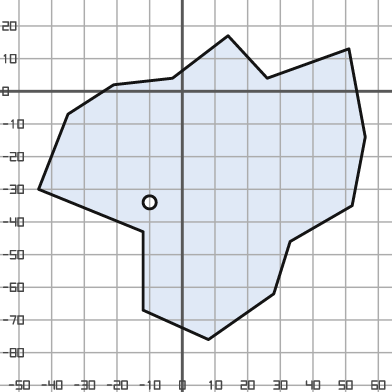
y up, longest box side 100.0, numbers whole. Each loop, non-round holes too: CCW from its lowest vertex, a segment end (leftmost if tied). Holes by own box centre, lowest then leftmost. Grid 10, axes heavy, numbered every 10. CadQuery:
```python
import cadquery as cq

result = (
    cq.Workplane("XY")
    .moveTo(8.0, -76.0)
    .lineTo(28.0, -62.0)
    .lineTo(33.0, -46.0)
    .lineTo(52.0, -35.0)
    .lineTo(56.0, -14.0)
    .lineTo(51.0, 13.0)
    .lineTo(26.0, 4.0)
    .lineTo(14.0, 17.0)
    .lineTo(-3.0, 4.0)
    .lineTo(-21.0, 2.0)
    .lineTo(-35.0, -7.0)
    .lineTo(-44.0, -30.0)
    .lineTo(-12.0, -43.0)
    .lineTo(-12.0, -67.0)
    .close()
    .moveTo(-10.0, -34.0)
    .circle(2.0)
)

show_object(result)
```